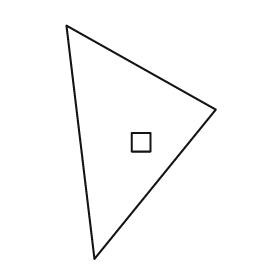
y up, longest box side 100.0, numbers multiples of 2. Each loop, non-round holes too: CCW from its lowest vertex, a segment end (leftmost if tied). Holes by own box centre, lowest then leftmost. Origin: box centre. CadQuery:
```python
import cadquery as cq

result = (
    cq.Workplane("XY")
    .moveTo(-20.0, -50.0)
    .lineTo(32.0, 14.0)
    .lineTo(-32.0, 50.0)
    .close()
    .moveTo(-4.0, -4.0)
    .lineTo(4.0, -4.0)
    .lineTo(4.0, 4.0)
    .lineTo(-4.0, 4.0)
    .close()
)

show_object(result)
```